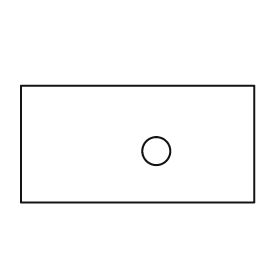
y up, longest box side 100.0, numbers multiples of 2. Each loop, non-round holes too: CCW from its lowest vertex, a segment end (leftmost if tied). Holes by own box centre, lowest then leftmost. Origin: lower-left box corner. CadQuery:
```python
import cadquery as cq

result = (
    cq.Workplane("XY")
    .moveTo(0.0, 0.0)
    .lineTo(100.0, 0.0)
    .lineTo(100.0, 50.0)
    .lineTo(0.0, 50.0)
    .close()
    .moveTo(58.0, 22.0)
    .circle(6.0)
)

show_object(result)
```